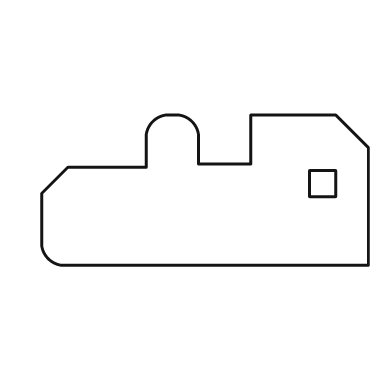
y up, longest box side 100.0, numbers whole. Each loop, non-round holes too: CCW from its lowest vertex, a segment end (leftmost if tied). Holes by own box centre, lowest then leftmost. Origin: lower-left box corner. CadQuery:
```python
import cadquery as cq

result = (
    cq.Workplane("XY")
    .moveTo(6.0, 0.0)
    .lineTo(100.0, 0.0)
    .lineTo(100.0, 36.0)
    .lineTo(90.0, 46.0)
    .lineTo(64.0, 46.0)
    .lineTo(64.0, 31.0)
    .lineTo(48.0, 31.0)
    .lineTo(48.0, 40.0)
    .threePointArc((46.0, 44.0), (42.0, 46.0))
    .lineTo(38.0, 46.0)
    .threePointArc((34.0, 44.0), (32.0, 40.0))
    .lineTo(32.0, 30.0)
    .lineTo(8.0, 30.0)
    .lineTo(0.0, 22.0)
    .lineTo(0.0, 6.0)
    .threePointArc((2.0, 2.0), (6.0, 0.0))
    .close()
    .moveTo(82.0, 21.0)
    .lineTo(90.0, 21.0)
    .lineTo(90.0, 29.0)
    .lineTo(82.0, 29.0)
    .close()
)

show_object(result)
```